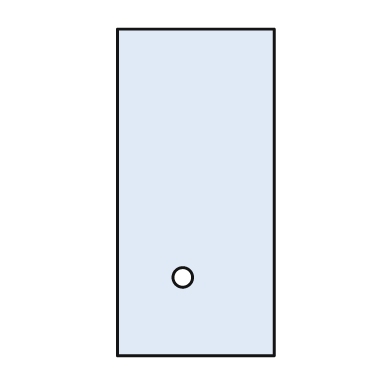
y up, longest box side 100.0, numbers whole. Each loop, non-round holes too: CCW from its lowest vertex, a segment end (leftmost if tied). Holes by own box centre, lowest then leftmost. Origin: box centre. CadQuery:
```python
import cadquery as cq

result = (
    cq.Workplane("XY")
    .moveTo(-24.0, -50.0)
    .lineTo(24.0, -50.0)
    .lineTo(24.0, 50.0)
    .lineTo(-24.0, 50.0)
    .close()
    .moveTo(-4.0, -26.0)
    .circle(3.0)
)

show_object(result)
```